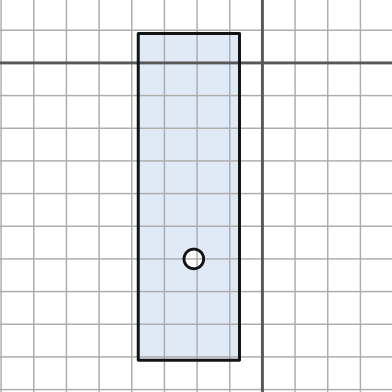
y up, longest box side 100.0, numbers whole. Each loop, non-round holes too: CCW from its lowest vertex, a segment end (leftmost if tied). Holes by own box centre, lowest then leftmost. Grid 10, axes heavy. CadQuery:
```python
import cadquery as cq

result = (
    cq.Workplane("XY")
    .moveTo(-38.0, -91.0)
    .lineTo(-7.0, -91.0)
    .lineTo(-7.0, 9.0)
    .lineTo(-38.0, 9.0)
    .close()
    .moveTo(-21.0, -60.0)
    .circle(3.0)
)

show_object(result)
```